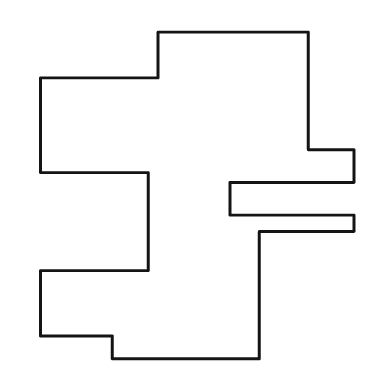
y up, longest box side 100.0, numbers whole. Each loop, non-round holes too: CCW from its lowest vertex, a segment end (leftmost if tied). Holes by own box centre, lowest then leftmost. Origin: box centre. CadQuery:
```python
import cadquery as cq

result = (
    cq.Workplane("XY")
    .moveTo(-26.0, -50.0)
    .lineTo(19.0, -50.0)
    .lineTo(19.0, -11.0)
    .lineTo(48.0, -11.0)
    .lineTo(48.0, -6.0)
    .lineTo(10.0, -6.0)
    .lineTo(10.0, 4.0)
    .lineTo(48.0, 4.0)
    .lineTo(48.0, 14.0)
    .lineTo(34.0, 14.0)
    .lineTo(34.0, 50.0)
    .lineTo(-12.0, 50.0)
    .lineTo(-12.0, 36.0)
    .lineTo(-48.0, 36.0)
    .lineTo(-48.0, 7.0)
    .lineTo(-15.0, 7.0)
    .lineTo(-15.0, -23.0)
    .lineTo(-48.0, -23.0)
    .lineTo(-48.0, -43.0)
    .lineTo(-26.0, -43.0)
    .close()
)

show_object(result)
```